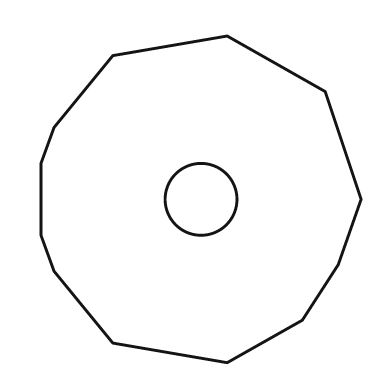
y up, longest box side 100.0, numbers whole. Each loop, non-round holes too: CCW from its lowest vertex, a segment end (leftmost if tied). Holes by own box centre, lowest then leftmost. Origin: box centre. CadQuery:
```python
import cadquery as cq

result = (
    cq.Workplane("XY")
    .moveTo(8.0, -50.0)
    .lineTo(31.0, -37.0)
    .lineTo(42.0, -20.0)
    .lineTo(49.0, 0.0)
    .lineTo(38.0, 33.0)
    .lineTo(8.0, 50.0)
    .lineTo(-27.0, 44.0)
    .lineTo(-45.0, 22.0)
    .lineTo(-49.0, 11.0)
    .lineTo(-49.0, -11.0)
    .lineTo(-45.0, -22.0)
    .lineTo(-27.0, -44.0)
    .close()
    .moveTo(0.0, 0.0)
    .circle(11.0)
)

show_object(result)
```